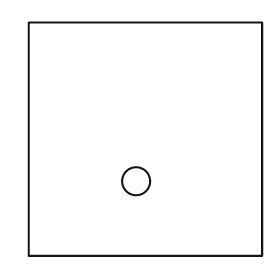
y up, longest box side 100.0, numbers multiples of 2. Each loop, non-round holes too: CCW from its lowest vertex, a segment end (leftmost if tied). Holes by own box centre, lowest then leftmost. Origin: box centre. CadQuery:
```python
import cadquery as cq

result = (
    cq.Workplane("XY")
    .moveTo(-50.0, -50.0)
    .lineTo(50.0, -50.0)
    .lineTo(50.0, 50.0)
    .lineTo(-50.0, 50.0)
    .close()
    .moveTo(-4.0, -18.0)
    .circle(6.0)
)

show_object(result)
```